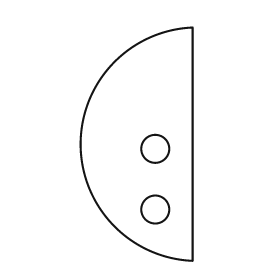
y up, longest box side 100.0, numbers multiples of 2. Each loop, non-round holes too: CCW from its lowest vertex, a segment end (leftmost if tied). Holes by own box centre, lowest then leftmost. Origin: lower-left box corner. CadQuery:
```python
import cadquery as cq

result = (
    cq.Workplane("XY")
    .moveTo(48.0, 0.0)
    .lineTo(48.0, 100.0)
    .threePointArc((0.0, 50.0), (48.0, 0.0))
    .close()
    .moveTo(32.0, 22.0)
    .circle(6.0)
    .moveTo(32.0, 48.0)
    .circle(6.0)
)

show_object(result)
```